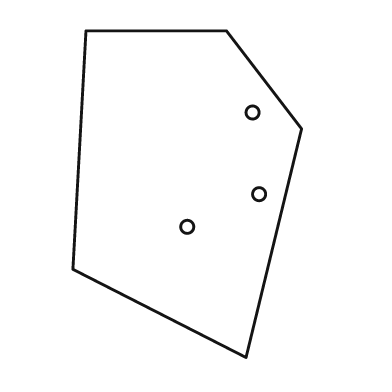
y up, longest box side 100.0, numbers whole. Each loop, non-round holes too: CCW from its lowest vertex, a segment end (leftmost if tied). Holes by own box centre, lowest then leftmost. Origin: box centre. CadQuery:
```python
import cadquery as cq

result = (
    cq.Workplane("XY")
    .moveTo(18.0, -50.0)
    .lineTo(35.0, 20.0)
    .lineTo(12.0, 50.0)
    .lineTo(-31.0, 50.0)
    .lineTo(-35.0, -23.0)
    .close()
    .moveTo(0.0, -10.0)
    .circle(2.0)
    .moveTo(22.0, 0.0)
    .circle(2.0)
    .moveTo(20.0, 25.0)
    .circle(2.0)
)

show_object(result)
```